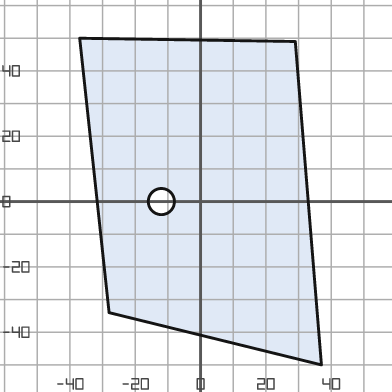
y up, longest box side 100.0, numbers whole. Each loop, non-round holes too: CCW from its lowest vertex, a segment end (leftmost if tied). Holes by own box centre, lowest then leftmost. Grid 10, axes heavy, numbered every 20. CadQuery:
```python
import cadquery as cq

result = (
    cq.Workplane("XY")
    .moveTo(37.0, -50.0)
    .lineTo(29.0, 49.0)
    .lineTo(-37.0, 50.0)
    .lineTo(-28.0, -34.0)
    .close()
    .moveTo(-12.0, 0.0)
    .circle(4.0)
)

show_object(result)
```